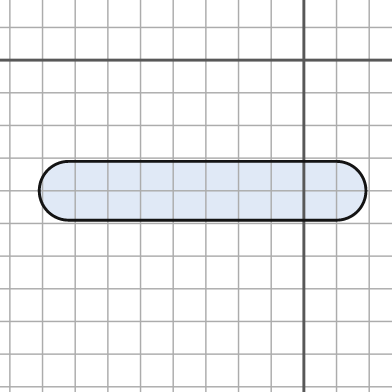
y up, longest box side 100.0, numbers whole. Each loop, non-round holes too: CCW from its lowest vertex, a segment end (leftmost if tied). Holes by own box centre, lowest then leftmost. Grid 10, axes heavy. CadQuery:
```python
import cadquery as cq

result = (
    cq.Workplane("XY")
    .moveTo(-72.0, -49.0)
    .lineTo(10.0, -49.0)
    .threePointArc((19.0, -40.0), (10.0, -31.0))
    .lineTo(-72.0, -31.0)
    .threePointArc((-81.0, -40.0), (-72.0, -49.0))
    .close()
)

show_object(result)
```